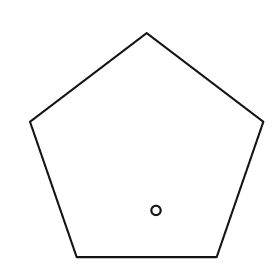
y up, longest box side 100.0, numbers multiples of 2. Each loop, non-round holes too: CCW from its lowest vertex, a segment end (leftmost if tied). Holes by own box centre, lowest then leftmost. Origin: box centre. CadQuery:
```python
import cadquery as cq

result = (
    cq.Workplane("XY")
    .moveTo(-30.0, -48.0)
    .lineTo(30.0, -48.0)
    .lineTo(50.0, 10.0)
    .lineTo(0.0, 48.0)
    .lineTo(-50.0, 10.0)
    .close()
    .moveTo(4.0, -28.0)
    .circle(2.0)
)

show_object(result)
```